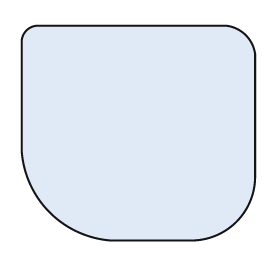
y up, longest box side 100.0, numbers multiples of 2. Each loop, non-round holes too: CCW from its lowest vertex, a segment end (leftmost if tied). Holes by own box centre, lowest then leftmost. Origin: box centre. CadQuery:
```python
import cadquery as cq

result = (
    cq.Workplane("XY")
    .moveTo(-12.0, -46.0)
    .lineTo(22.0, -46.0)
    .threePointArc((42.0, -38.0), (50.0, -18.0))
    .lineTo(50.0, 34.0)
    .threePointArc((46.0, 42.0), (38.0, 46.0))
    .lineTo(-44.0, 46.0)
    .threePointArc((-48.0, 44.0), (-50.0, 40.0))
    .lineTo(-50.0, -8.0)
    .threePointArc((-38.0, -34.0), (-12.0, -46.0))
    .close()
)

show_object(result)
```